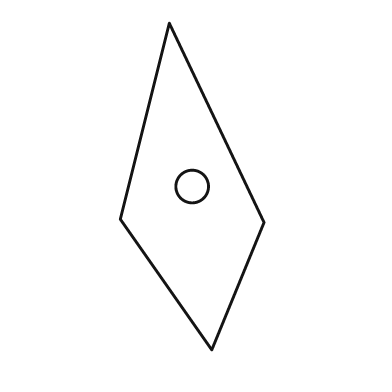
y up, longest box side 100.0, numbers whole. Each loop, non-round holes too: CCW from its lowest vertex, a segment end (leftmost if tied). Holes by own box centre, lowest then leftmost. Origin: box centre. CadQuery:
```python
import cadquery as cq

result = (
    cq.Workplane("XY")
    .moveTo(6.0, -50.0)
    .lineTo(22.0, -11.0)
    .lineTo(-7.0, 50.0)
    .lineTo(-22.0, -10.0)
    .close()
    .moveTo(0.0, 0.0)
    .circle(5.0)
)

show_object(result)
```